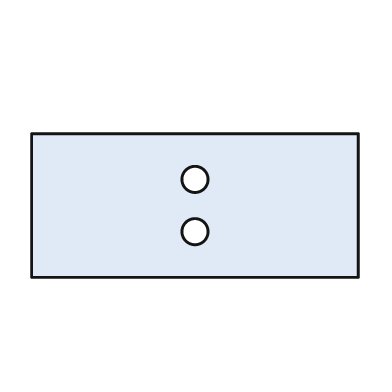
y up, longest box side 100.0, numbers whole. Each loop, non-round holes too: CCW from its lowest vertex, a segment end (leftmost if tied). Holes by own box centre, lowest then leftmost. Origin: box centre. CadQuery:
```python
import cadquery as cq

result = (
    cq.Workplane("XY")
    .moveTo(-50.0, -22.0)
    .lineTo(50.0, -22.0)
    .lineTo(50.0, 22.0)
    .lineTo(-50.0, 22.0)
    .close()
    .moveTo(0.0, -8.0)
    .circle(4.0)
    .moveTo(0.0, 8.0)
    .circle(4.0)
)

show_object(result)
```